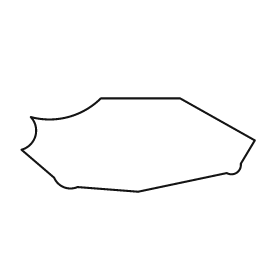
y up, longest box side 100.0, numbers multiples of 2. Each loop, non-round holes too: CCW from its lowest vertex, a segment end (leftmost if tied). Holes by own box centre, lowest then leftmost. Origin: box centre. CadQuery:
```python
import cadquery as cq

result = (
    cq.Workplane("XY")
    .moveTo(0.0, -20.0)
    .lineTo(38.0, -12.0)
    .threePointArc((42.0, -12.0), (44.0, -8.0))
    .lineTo(50.0, 2.0)
    .lineTo(18.0, 20.0)
    .lineTo(-16.0, 20.0)
    .threePointArc((-30.0, 12.0), (-46.0, 12.0))
    .threePointArc((-44.0, 4.0), (-50.0, -2.0))
    .lineTo(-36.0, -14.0)
    .threePointArc((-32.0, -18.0), (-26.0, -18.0))
    .close()
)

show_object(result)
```